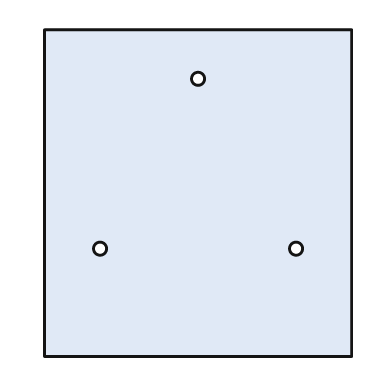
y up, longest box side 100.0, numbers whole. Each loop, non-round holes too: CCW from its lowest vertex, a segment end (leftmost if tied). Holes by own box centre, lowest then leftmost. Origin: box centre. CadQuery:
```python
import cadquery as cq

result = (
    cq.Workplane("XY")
    .moveTo(-47.0, -50.0)
    .lineTo(47.0, -50.0)
    .lineTo(47.0, 50.0)
    .lineTo(-47.0, 50.0)
    .close()
    .moveTo(-30.0, -17.0)
    .circle(2.0)
    .moveTo(30.0, -17.0)
    .circle(2.0)
    .moveTo(0.0, 35.0)
    .circle(2.0)
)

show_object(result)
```